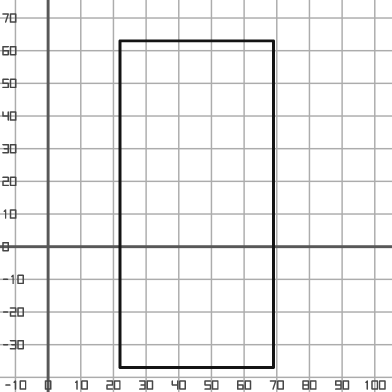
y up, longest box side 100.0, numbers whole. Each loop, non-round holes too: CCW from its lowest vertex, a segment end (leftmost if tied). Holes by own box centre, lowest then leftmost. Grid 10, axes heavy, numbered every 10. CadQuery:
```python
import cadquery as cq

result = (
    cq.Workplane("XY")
    .moveTo(22.0, -37.0)
    .lineTo(69.0, -37.0)
    .lineTo(69.0, 63.0)
    .lineTo(22.0, 63.0)
    .close()
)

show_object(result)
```